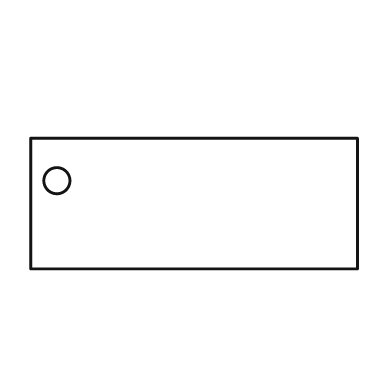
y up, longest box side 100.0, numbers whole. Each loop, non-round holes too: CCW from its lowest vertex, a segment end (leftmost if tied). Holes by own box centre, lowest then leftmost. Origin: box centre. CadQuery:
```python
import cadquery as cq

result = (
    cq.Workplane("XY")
    .moveTo(-50.0, -20.0)
    .lineTo(50.0, -20.0)
    .lineTo(50.0, 20.0)
    .lineTo(-50.0, 20.0)
    .close()
    .moveTo(-42.0, 7.0)
    .circle(4.0)
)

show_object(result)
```